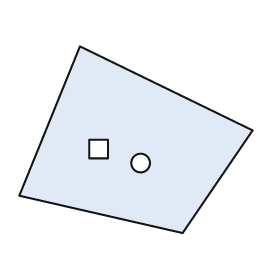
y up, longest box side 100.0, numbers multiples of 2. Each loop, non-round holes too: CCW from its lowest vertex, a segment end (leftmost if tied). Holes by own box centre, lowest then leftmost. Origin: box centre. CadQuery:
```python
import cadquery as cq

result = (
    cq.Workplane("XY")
    .moveTo(20.0, -40.0)
    .lineTo(50.0, 4.0)
    .lineTo(-24.0, 40.0)
    .lineTo(-50.0, -24.0)
    .close()
    .moveTo(2.0, -10.0)
    .circle(4.0)
    .moveTo(-20.0, -8.0)
    .lineTo(-12.0, -8.0)
    .lineTo(-12.0, 0.0)
    .lineTo(-20.0, 0.0)
    .close()
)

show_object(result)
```